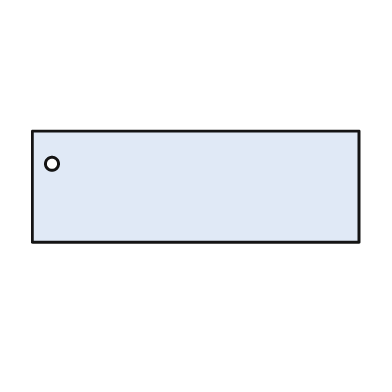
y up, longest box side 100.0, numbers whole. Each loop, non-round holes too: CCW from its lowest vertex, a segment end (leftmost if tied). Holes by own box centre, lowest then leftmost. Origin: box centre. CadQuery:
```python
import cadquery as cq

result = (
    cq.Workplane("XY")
    .moveTo(-50.0, -17.0)
    .lineTo(50.0, -17.0)
    .lineTo(50.0, 17.0)
    .lineTo(-50.0, 17.0)
    .close()
    .moveTo(-44.0, 7.0)
    .circle(2.0)
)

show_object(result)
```